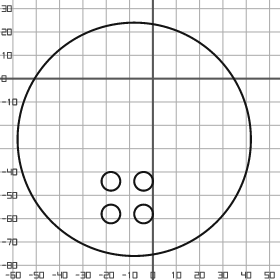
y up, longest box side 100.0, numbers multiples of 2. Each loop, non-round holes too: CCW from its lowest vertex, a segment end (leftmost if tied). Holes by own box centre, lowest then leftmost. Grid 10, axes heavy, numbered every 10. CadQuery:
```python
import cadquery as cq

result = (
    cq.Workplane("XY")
    .moveTo(-8.0, -26.0)
    .circle(50.0)
    .moveTo(-18.0, -58.0)
    .circle(4.0)
    .moveTo(-4.0, -58.0)
    .circle(4.0)
    .moveTo(-18.0, -44.0)
    .circle(4.0)
    .moveTo(-4.0, -44.0)
    .circle(4.0)
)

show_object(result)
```